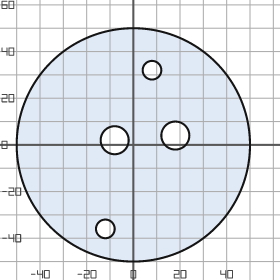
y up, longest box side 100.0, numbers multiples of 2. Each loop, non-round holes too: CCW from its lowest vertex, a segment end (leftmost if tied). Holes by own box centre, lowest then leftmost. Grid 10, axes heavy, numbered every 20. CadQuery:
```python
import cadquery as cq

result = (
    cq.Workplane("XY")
    .moveTo(0.0, 0.0)
    .circle(50.0)
    .moveTo(-12.0, -36.0)
    .circle(4.0)
    .moveTo(-8.0, 2.0)
    .circle(6.0)
    .moveTo(18.0, 4.0)
    .circle(6.0)
    .moveTo(8.0, 32.0)
    .circle(4.0)
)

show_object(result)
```